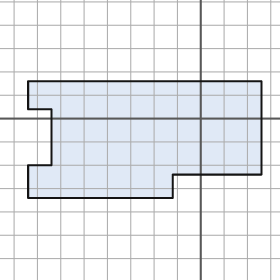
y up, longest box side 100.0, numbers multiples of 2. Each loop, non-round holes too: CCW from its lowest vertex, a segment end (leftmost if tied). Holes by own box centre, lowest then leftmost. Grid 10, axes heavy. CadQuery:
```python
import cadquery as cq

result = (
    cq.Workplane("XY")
    .moveTo(-74.0, -34.0)
    .lineTo(-12.0, -34.0)
    .lineTo(-12.0, -24.0)
    .lineTo(26.0, -24.0)
    .lineTo(26.0, 16.0)
    .lineTo(-74.0, 16.0)
    .lineTo(-74.0, 4.0)
    .lineTo(-64.0, 4.0)
    .lineTo(-64.0, -20.0)
    .lineTo(-74.0, -20.0)
    .close()
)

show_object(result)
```